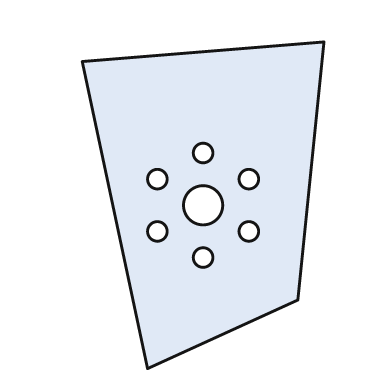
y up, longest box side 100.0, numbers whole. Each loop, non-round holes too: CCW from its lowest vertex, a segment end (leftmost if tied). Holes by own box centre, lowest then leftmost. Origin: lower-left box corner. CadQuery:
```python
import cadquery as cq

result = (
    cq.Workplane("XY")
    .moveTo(20.0, 0.0)
    .lineTo(66.0, 21.0)
    .lineTo(74.0, 100.0)
    .lineTo(0.0, 94.0)
    .close()
    .moveTo(37.0, 34.0)
    .circle(3.0)
    .moveTo(23.0, 42.0)
    .circle(3.0)
    .moveTo(51.0, 42.0)
    .circle(3.0)
    .moveTo(37.0, 50.0)
    .circle(6.0)
    .moveTo(23.0, 58.0)
    .circle(3.0)
    .moveTo(51.0, 58.0)
    .circle(3.0)
    .moveTo(37.0, 66.0)
    .circle(3.0)
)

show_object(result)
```